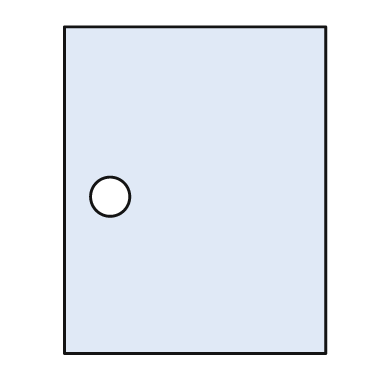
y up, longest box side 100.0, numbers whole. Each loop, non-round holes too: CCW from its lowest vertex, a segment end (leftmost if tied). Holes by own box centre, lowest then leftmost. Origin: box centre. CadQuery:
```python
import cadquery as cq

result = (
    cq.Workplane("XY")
    .moveTo(-40.0, -50.0)
    .lineTo(40.0, -50.0)
    .lineTo(40.0, 50.0)
    .lineTo(-40.0, 50.0)
    .close()
    .moveTo(-26.0, -2.0)
    .circle(6.0)
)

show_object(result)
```